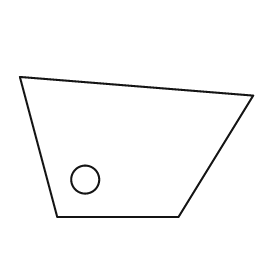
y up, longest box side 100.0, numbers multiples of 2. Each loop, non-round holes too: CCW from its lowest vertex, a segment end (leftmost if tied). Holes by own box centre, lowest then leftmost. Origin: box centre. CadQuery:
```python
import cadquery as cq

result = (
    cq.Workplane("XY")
    .moveTo(-34.0, -30.0)
    .lineTo(18.0, -30.0)
    .lineTo(50.0, 22.0)
    .lineTo(-50.0, 30.0)
    .close()
    .moveTo(-22.0, -14.0)
    .circle(6.0)
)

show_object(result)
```